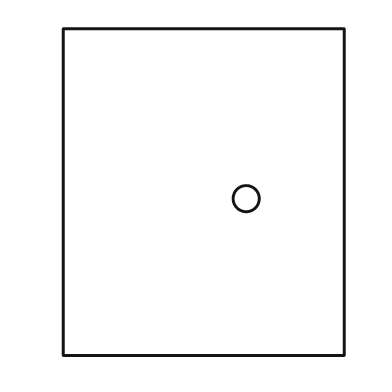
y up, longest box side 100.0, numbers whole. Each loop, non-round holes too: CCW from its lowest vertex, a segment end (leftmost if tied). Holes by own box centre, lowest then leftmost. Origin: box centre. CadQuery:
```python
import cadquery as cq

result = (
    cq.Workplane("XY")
    .moveTo(-43.0, -50.0)
    .lineTo(43.0, -50.0)
    .lineTo(43.0, 50.0)
    .lineTo(-43.0, 50.0)
    .close()
    .moveTo(13.0, -2.0)
    .circle(4.0)
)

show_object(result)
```